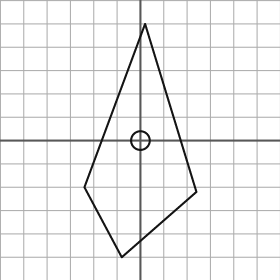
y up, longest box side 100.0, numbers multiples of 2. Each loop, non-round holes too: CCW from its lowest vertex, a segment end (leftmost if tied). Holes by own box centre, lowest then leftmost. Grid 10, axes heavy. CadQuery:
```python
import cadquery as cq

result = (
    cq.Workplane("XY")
    .moveTo(-8.0, -50.0)
    .lineTo(24.0, -22.0)
    .lineTo(2.0, 50.0)
    .lineTo(-24.0, -20.0)
    .close()
    .moveTo(0.0, 0.0)
    .circle(4.0)
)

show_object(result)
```